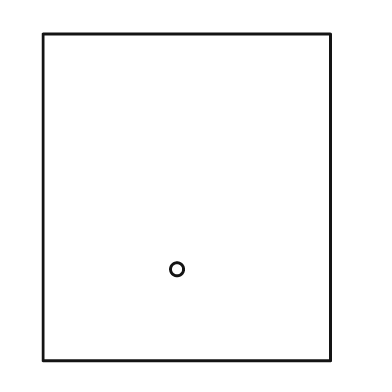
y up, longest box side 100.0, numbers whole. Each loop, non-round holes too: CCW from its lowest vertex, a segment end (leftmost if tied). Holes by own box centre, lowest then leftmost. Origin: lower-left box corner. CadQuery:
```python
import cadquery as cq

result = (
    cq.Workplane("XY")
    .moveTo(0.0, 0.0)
    .lineTo(88.0, 0.0)
    .lineTo(88.0, 100.0)
    .lineTo(0.0, 100.0)
    .close()
    .moveTo(41.0, 28.0)
    .circle(2.0)
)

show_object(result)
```